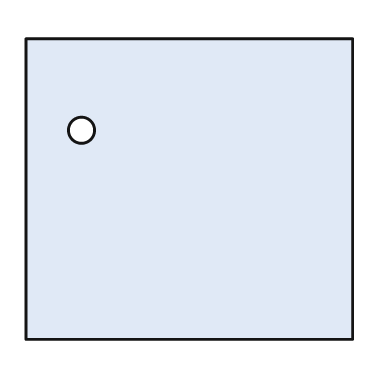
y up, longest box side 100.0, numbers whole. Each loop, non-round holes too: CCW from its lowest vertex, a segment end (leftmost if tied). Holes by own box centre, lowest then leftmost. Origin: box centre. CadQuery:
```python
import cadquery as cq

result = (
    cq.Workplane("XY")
    .moveTo(-50.0, -46.0)
    .lineTo(50.0, -46.0)
    .lineTo(50.0, 46.0)
    .lineTo(-50.0, 46.0)
    .close()
    .moveTo(-33.0, 18.0)
    .circle(4.0)
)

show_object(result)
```